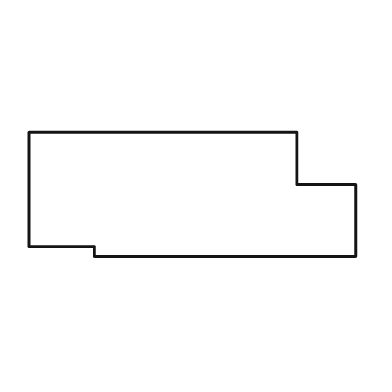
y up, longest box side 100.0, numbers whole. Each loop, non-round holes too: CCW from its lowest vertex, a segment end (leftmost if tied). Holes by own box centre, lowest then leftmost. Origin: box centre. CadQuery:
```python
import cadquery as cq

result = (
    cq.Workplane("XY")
    .moveTo(-30.0, -19.0)
    .lineTo(50.0, -19.0)
    .lineTo(50.0, 3.0)
    .lineTo(32.0, 3.0)
    .lineTo(32.0, 19.0)
    .lineTo(-50.0, 19.0)
    .lineTo(-50.0, -16.0)
    .lineTo(-30.0, -16.0)
    .close()
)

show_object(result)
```